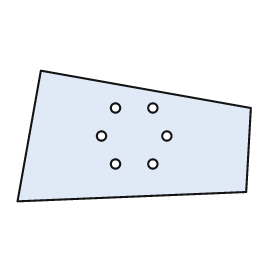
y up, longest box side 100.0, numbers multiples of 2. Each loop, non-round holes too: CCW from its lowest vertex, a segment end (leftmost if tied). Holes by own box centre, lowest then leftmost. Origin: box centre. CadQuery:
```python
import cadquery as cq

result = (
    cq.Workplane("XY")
    .moveTo(-50.0, -28.0)
    .lineTo(48.0, -24.0)
    .lineTo(50.0, 12.0)
    .lineTo(-40.0, 28.0)
    .close()
    .moveTo(-8.0, -12.0)
    .circle(2.0)
    .moveTo(8.0, -12.0)
    .circle(2.0)
    .moveTo(-14.0, 0.0)
    .circle(2.0)
    .moveTo(14.0, 0.0)
    .circle(2.0)
    .moveTo(-8.0, 12.0)
    .circle(2.0)
    .moveTo(8.0, 12.0)
    .circle(2.0)
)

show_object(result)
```